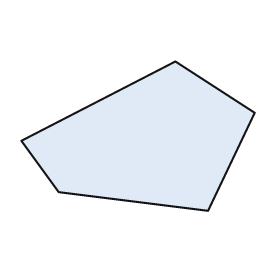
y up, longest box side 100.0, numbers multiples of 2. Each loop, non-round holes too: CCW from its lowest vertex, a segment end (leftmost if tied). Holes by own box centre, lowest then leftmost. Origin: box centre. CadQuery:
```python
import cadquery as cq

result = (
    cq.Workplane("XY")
    .moveTo(30.0, -32.0)
    .lineTo(50.0, 10.0)
    .lineTo(16.0, 32.0)
    .lineTo(-50.0, -2.0)
    .lineTo(-34.0, -24.0)
    .close()
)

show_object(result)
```